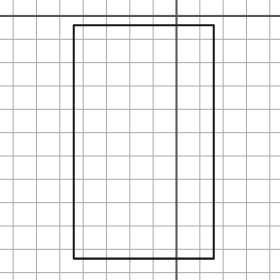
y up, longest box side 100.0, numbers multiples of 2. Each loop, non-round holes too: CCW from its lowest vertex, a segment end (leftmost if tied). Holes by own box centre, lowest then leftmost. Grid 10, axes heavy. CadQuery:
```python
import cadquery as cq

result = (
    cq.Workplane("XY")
    .moveTo(-44.0, -104.0)
    .lineTo(16.0, -104.0)
    .lineTo(16.0, -4.0)
    .lineTo(-44.0, -4.0)
    .close()
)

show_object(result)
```